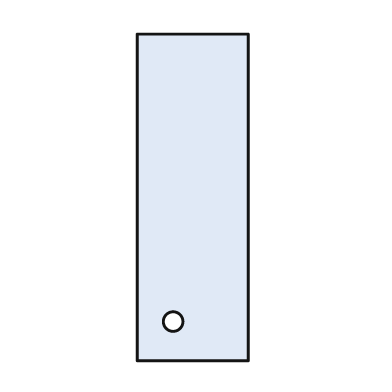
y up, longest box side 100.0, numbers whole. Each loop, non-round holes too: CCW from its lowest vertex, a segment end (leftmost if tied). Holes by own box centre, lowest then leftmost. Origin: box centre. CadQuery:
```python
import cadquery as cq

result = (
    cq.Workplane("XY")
    .moveTo(-17.0, -50.0)
    .lineTo(17.0, -50.0)
    .lineTo(17.0, 50.0)
    .lineTo(-17.0, 50.0)
    .close()
    .moveTo(-6.0, -38.0)
    .circle(3.0)
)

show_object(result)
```